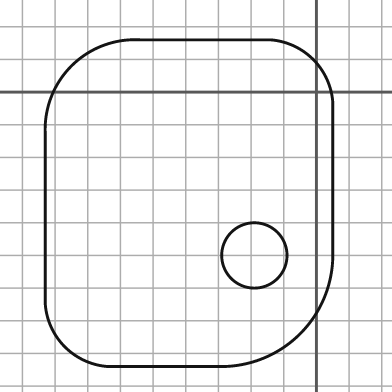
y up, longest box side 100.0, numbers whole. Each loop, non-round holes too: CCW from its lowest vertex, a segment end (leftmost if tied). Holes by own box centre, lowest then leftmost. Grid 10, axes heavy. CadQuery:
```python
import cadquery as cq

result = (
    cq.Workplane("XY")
    .moveTo(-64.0, -84.0)
    .lineTo(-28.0, -84.0)
    .threePointArc((-5.0, -74.0), (5.0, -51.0))
    .lineTo(5.0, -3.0)
    .threePointArc((-1.0, 10.0), (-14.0, 16.0))
    .lineTo(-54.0, 16.0)
    .threePointArc((-75.0, 8.0), (-83.0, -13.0))
    .lineTo(-83.0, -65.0)
    .threePointArc((-77.0, -78.0), (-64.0, -84.0))
    .close()
    .moveTo(-19.0, -50.0)
    .circle(10.0)
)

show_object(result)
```